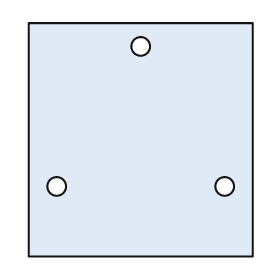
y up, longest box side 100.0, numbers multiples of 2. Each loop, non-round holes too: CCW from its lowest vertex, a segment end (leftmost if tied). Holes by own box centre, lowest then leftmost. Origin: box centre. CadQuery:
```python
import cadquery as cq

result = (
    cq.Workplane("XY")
    .moveTo(-48.0, -50.0)
    .lineTo(48.0, -50.0)
    .lineTo(48.0, 50.0)
    .lineTo(-48.0, 50.0)
    .close()
    .moveTo(-36.0, -20.0)
    .circle(4.0)
    .moveTo(36.0, -20.0)
    .circle(4.0)
    .moveTo(0.0, 40.0)
    .circle(4.0)
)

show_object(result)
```